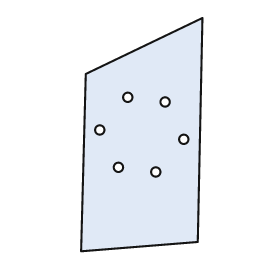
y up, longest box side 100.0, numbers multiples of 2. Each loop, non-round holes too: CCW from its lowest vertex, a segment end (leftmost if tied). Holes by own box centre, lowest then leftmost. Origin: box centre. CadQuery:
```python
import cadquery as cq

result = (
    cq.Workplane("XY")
    .moveTo(-26.0, -50.0)
    .lineTo(24.0, -46.0)
    .lineTo(26.0, 50.0)
    .lineTo(-24.0, 26.0)
    .close()
    .moveTo(6.0, -16.0)
    .circle(2.0)
    .moveTo(-10.0, -14.0)
    .circle(2.0)
    .moveTo(18.0, -2.0)
    .circle(2.0)
    .moveTo(-18.0, 2.0)
    .circle(2.0)
    .moveTo(10.0, 14.0)
    .circle(2.0)
    .moveTo(-6.0, 16.0)
    .circle(2.0)
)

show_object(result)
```